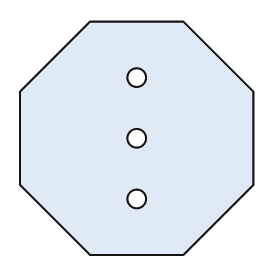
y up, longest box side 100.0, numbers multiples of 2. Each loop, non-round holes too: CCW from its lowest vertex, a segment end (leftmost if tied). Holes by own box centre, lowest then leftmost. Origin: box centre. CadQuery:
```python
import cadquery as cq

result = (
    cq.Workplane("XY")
    .moveTo(-20.0, -50.0)
    .lineTo(20.0, -50.0)
    .lineTo(50.0, -20.0)
    .lineTo(50.0, 20.0)
    .lineTo(20.0, 50.0)
    .lineTo(-20.0, 50.0)
    .lineTo(-50.0, 20.0)
    .lineTo(-50.0, -20.0)
    .close()
    .moveTo(0.0, -26.0)
    .circle(4.0)
    .moveTo(0.0, 0.0)
    .circle(4.0)
    .moveTo(0.0, 26.0)
    .circle(4.0)
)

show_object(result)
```